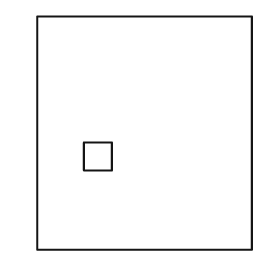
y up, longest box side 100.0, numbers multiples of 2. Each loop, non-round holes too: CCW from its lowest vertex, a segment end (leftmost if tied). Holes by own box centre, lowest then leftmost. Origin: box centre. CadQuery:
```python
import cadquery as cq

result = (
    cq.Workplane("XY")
    .moveTo(-46.0, -50.0)
    .lineTo(46.0, -50.0)
    .lineTo(46.0, 50.0)
    .lineTo(-46.0, 50.0)
    .close()
    .moveTo(-26.0, -16.0)
    .lineTo(-14.0, -16.0)
    .lineTo(-14.0, -4.0)
    .lineTo(-26.0, -4.0)
    .close()
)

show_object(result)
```